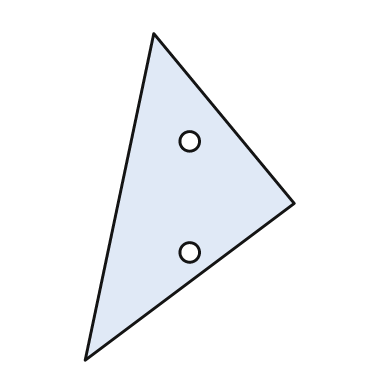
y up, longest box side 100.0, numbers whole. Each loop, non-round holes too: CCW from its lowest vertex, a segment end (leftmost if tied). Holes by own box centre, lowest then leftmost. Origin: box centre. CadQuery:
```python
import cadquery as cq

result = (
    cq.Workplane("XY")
    .moveTo(-32.0, -50.0)
    .lineTo(32.0, -2.0)
    .lineTo(-11.0, 50.0)
    .close()
    .moveTo(0.0, -17.0)
    .circle(3.0)
    .moveTo(0.0, 17.0)
    .circle(3.0)
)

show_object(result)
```